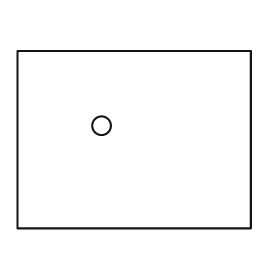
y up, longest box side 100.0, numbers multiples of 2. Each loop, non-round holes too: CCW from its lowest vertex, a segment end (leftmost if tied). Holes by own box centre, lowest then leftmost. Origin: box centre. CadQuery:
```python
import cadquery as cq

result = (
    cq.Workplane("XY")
    .moveTo(-50.0, -38.0)
    .lineTo(50.0, -38.0)
    .lineTo(50.0, 38.0)
    .lineTo(-50.0, 38.0)
    .close()
    .moveTo(-14.0, 6.0)
    .circle(4.0)
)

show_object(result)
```